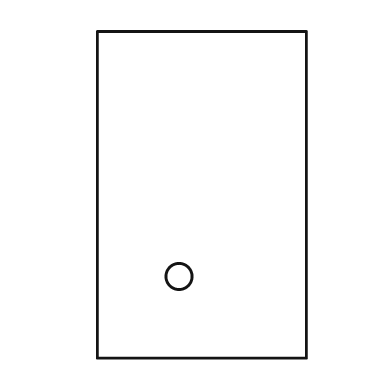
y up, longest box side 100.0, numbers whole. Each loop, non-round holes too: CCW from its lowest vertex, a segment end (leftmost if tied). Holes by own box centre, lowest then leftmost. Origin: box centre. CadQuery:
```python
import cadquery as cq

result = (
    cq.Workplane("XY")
    .moveTo(-32.0, -50.0)
    .lineTo(32.0, -50.0)
    .lineTo(32.0, 50.0)
    .lineTo(-32.0, 50.0)
    .close()
    .moveTo(-7.0, -25.0)
    .circle(4.0)
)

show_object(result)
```